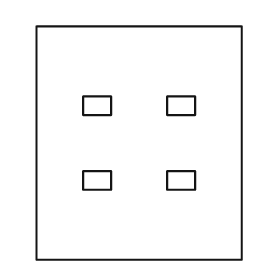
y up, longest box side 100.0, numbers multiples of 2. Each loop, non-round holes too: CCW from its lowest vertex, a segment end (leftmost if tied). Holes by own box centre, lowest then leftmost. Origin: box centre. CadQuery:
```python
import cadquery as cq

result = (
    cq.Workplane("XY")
    .moveTo(-44.0, -50.0)
    .lineTo(44.0, -50.0)
    .lineTo(44.0, 50.0)
    .lineTo(-44.0, 50.0)
    .close()
    .moveTo(-24.0, -20.0)
    .lineTo(-12.0, -20.0)
    .lineTo(-12.0, -12.0)
    .lineTo(-24.0, -12.0)
    .close()
    .moveTo(12.0, -20.0)
    .lineTo(24.0, -20.0)
    .lineTo(24.0, -12.0)
    .lineTo(12.0, -12.0)
    .close()
    .moveTo(-24.0, 12.0)
    .lineTo(-12.0, 12.0)
    .lineTo(-12.0, 20.0)
    .lineTo(-24.0, 20.0)
    .close()
    .moveTo(12.0, 12.0)
    .lineTo(24.0, 12.0)
    .lineTo(24.0, 20.0)
    .lineTo(12.0, 20.0)
    .close()
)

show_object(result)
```